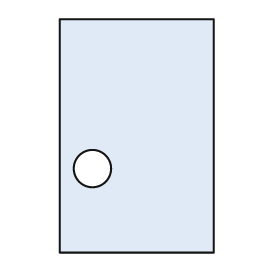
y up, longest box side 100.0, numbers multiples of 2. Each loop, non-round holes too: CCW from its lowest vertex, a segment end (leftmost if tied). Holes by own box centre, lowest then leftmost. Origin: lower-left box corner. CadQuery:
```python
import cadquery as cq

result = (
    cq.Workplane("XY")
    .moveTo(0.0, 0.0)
    .lineTo(66.0, 0.0)
    .lineTo(66.0, 100.0)
    .lineTo(0.0, 100.0)
    .close()
    .moveTo(14.0, 36.0)
    .circle(8.0)
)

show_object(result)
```